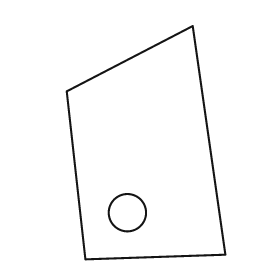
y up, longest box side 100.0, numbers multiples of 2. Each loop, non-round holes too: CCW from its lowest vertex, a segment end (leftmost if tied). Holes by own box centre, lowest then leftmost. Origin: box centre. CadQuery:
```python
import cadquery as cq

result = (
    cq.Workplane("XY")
    .moveTo(-26.0, -50.0)
    .lineTo(34.0, -48.0)
    .lineTo(20.0, 50.0)
    .lineTo(-34.0, 22.0)
    .close()
    .moveTo(-8.0, -30.0)
    .circle(8.0)
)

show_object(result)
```